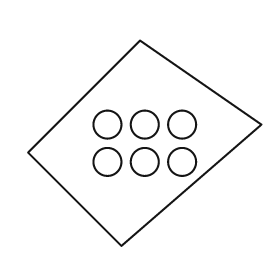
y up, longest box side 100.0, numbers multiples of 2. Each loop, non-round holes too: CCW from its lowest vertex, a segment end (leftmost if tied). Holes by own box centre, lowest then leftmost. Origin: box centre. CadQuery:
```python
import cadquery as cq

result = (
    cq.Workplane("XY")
    .moveTo(-10.0, -44.0)
    .lineTo(50.0, 8.0)
    .lineTo(-2.0, 44.0)
    .lineTo(-50.0, -4.0)
    .close()
    .moveTo(-16.0, -8.0)
    .circle(6.0)
    .moveTo(0.0, -8.0)
    .circle(6.0)
    .moveTo(16.0, -8.0)
    .circle(6.0)
    .moveTo(-16.0, 8.0)
    .circle(6.0)
    .moveTo(0.0, 8.0)
    .circle(6.0)
    .moveTo(16.0, 8.0)
    .circle(6.0)
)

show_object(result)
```